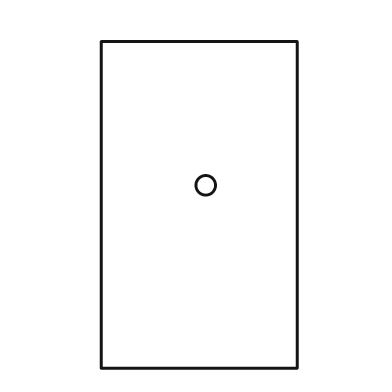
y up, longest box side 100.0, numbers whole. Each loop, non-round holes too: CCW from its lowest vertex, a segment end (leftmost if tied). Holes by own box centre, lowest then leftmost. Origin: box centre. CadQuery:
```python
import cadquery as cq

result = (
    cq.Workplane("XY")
    .moveTo(-30.0, -50.0)
    .lineTo(30.0, -50.0)
    .lineTo(30.0, 50.0)
    .lineTo(-30.0, 50.0)
    .close()
    .moveTo(2.0, 6.0)
    .circle(3.0)
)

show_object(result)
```